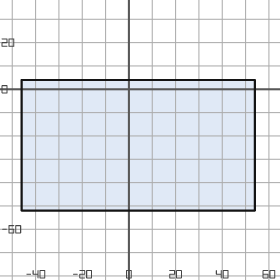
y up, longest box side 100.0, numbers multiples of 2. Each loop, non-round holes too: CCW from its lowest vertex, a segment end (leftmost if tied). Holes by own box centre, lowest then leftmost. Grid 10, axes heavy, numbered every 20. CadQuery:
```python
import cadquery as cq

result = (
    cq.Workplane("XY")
    .moveTo(-46.0, -52.0)
    .lineTo(54.0, -52.0)
    .lineTo(54.0, 4.0)
    .lineTo(-46.0, 4.0)
    .close()
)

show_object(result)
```